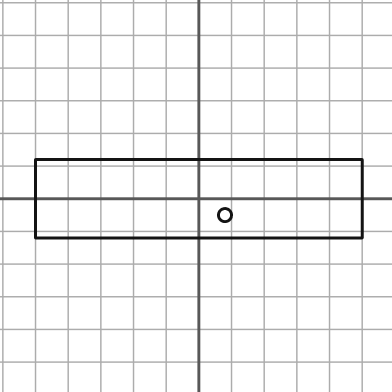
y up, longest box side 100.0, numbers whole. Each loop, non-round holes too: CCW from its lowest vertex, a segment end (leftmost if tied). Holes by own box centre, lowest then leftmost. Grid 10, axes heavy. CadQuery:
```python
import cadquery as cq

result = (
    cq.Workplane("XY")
    .moveTo(-50.0, -12.0)
    .lineTo(50.0, -12.0)
    .lineTo(50.0, 12.0)
    .lineTo(-50.0, 12.0)
    .close()
    .moveTo(8.0, -5.0)
    .circle(2.0)
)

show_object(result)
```